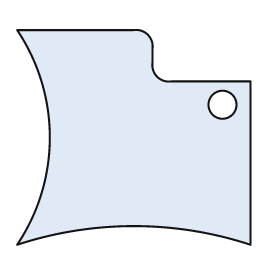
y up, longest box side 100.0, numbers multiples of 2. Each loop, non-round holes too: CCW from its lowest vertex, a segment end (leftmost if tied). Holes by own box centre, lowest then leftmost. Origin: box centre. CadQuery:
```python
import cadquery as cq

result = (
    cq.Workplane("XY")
    .moveTo(-50.0, -46.0)
    .threePointArc((0.0, -38.0), (50.0, -46.0))
    .lineTo(50.0, 24.0)
    .lineTo(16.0, 24.0)
    .threePointArc((10.0, 26.0), (8.0, 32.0))
    .lineTo(8.0, 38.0)
    .threePointArc((6.0, 44.0), (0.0, 46.0))
    .lineTo(-50.0, 46.0)
    .threePointArc((-36.0, 0.0), (-50.0, -46.0))
    .close()
    .moveTo(38.0, 14.0)
    .circle(6.0)
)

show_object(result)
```